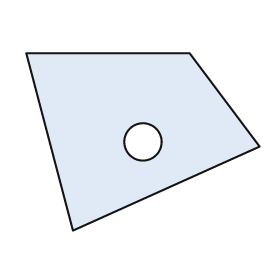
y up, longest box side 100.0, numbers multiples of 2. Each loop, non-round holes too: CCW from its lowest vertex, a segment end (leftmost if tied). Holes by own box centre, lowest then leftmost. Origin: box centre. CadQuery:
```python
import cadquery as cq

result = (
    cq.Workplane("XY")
    .moveTo(-30.0, -38.0)
    .lineTo(50.0, -2.0)
    .lineTo(20.0, 38.0)
    .lineTo(-50.0, 38.0)
    .close()
    .moveTo(0.0, 0.0)
    .circle(8.0)
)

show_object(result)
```